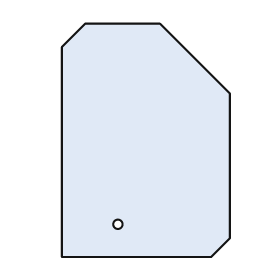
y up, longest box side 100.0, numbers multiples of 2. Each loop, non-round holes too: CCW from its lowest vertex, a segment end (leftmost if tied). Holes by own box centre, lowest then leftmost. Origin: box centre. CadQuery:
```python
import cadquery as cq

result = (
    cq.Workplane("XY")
    .moveTo(-36.0, -50.0)
    .lineTo(28.0, -50.0)
    .lineTo(36.0, -42.0)
    .lineTo(36.0, 20.0)
    .lineTo(6.0, 50.0)
    .lineTo(-26.0, 50.0)
    .lineTo(-36.0, 40.0)
    .close()
    .moveTo(-12.0, -36.0)
    .circle(2.0)
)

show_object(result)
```